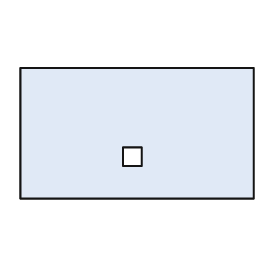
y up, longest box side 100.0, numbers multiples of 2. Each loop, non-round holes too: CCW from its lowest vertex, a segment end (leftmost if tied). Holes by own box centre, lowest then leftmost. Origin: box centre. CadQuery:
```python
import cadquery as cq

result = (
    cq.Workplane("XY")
    .moveTo(-50.0, -28.0)
    .lineTo(50.0, -28.0)
    .lineTo(50.0, 28.0)
    .lineTo(-50.0, 28.0)
    .close()
    .moveTo(-6.0, -14.0)
    .lineTo(2.0, -14.0)
    .lineTo(2.0, -6.0)
    .lineTo(-6.0, -6.0)
    .close()
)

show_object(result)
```